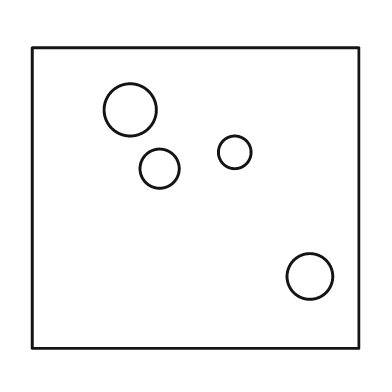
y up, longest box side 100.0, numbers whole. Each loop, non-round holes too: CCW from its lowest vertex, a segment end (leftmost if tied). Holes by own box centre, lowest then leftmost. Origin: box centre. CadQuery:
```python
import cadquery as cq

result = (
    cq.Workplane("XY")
    .moveTo(-50.0, -46.0)
    .lineTo(50.0, -46.0)
    .lineTo(50.0, 46.0)
    .lineTo(-50.0, 46.0)
    .close()
    .moveTo(35.0, -24.0)
    .circle(7.0)
    .moveTo(-11.0, 9.0)
    .circle(6.0)
    .moveTo(12.0, 14.0)
    .circle(5.0)
    .moveTo(-20.0, 27.0)
    .circle(8.0)
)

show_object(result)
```